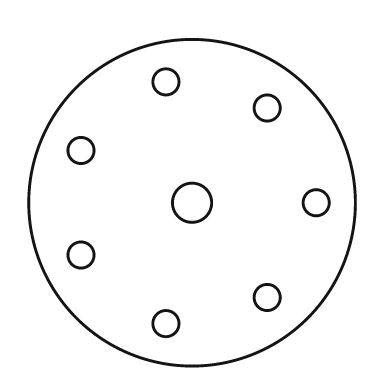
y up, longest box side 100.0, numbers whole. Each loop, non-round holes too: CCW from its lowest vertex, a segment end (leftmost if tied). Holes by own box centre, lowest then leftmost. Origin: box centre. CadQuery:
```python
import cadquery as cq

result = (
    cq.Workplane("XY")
    .moveTo(0.0, 0.0)
    .circle(50.0)
    .moveTo(-8.0, -37.0)
    .circle(4.0)
    .moveTo(23.0, -29.0)
    .circle(4.0)
    .moveTo(-34.0, -16.0)
    .circle(4.0)
    .moveTo(0.0, 0.0)
    .circle(6.0)
    .moveTo(38.0, 0.0)
    .circle(4.0)
    .moveTo(-34.0, 16.0)
    .circle(4.0)
    .moveTo(23.0, 29.0)
    .circle(4.0)
    .moveTo(-8.0, 37.0)
    .circle(4.0)
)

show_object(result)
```